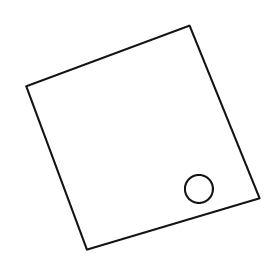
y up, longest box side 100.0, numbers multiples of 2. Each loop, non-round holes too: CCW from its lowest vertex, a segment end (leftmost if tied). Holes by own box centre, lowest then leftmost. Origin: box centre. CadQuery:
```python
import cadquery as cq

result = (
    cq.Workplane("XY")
    .moveTo(-24.0, -48.0)
    .lineTo(50.0, -26.0)
    .lineTo(20.0, 48.0)
    .lineTo(-50.0, 22.0)
    .close()
    .moveTo(24.0, -22.0)
    .circle(6.0)
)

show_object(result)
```